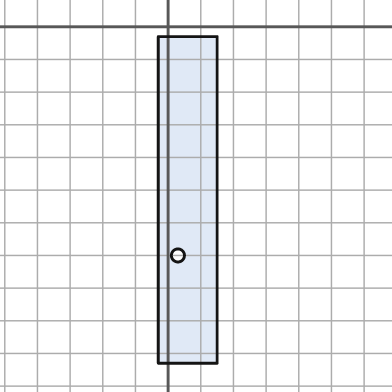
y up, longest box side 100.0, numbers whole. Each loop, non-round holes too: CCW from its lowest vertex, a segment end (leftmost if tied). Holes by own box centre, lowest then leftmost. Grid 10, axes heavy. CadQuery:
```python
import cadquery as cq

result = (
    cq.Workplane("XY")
    .moveTo(-3.0, -103.0)
    .lineTo(15.0, -103.0)
    .lineTo(15.0, -3.0)
    .lineTo(-3.0, -3.0)
    .close()
    .moveTo(3.0, -70.0)
    .circle(2.0)
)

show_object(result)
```